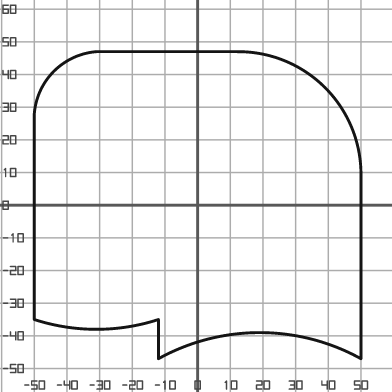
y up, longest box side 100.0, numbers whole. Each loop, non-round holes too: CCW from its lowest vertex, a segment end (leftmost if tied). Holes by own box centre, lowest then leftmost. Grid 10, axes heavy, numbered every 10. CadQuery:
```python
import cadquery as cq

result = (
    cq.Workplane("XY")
    .moveTo(-12.0, -47.0)
    .threePointArc((19.0, -39.0), (50.0, -47.0))
    .lineTo(50.0, 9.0)
    .threePointArc((39.0, 36.0), (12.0, 47.0))
    .lineTo(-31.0, 47.0)
    .threePointArc((-44.0, 41.0), (-50.0, 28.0))
    .lineTo(-50.0, -35.0)
    .threePointArc((-31.0, -38.0), (-12.0, -35.0))
    .close()
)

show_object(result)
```